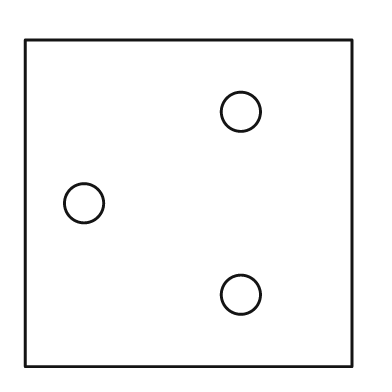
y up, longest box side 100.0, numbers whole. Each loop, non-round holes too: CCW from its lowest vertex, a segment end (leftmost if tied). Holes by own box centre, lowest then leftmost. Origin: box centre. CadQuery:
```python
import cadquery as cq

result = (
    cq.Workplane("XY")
    .moveTo(-50.0, -50.0)
    .lineTo(50.0, -50.0)
    .lineTo(50.0, 50.0)
    .lineTo(-50.0, 50.0)
    .close()
    .moveTo(16.0, -28.0)
    .circle(6.0)
    .moveTo(-32.0, 0.0)
    .circle(6.0)
    .moveTo(16.0, 28.0)
    .circle(6.0)
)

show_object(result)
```